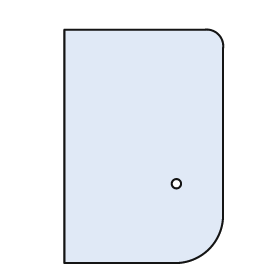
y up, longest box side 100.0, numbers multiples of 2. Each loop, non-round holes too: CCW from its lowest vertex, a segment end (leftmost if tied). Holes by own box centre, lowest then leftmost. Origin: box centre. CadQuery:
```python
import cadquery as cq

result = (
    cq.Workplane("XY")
    .moveTo(-34.0, -50.0)
    .lineTo(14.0, -50.0)
    .threePointArc((28.0, -44.0), (34.0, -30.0))
    .lineTo(34.0, 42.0)
    .threePointArc((32.0, 48.0), (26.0, 50.0))
    .lineTo(-34.0, 50.0)
    .close()
    .moveTo(14.0, -16.0)
    .circle(2.0)
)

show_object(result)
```